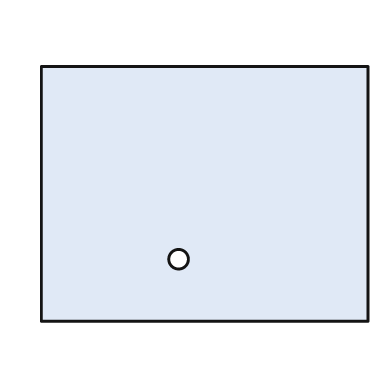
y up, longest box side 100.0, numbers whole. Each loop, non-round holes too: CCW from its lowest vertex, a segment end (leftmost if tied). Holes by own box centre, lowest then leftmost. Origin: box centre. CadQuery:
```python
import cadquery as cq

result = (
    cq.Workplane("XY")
    .moveTo(-50.0, -39.0)
    .lineTo(50.0, -39.0)
    .lineTo(50.0, 39.0)
    .lineTo(-50.0, 39.0)
    .close()
    .moveTo(-8.0, -20.0)
    .circle(3.0)
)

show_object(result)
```